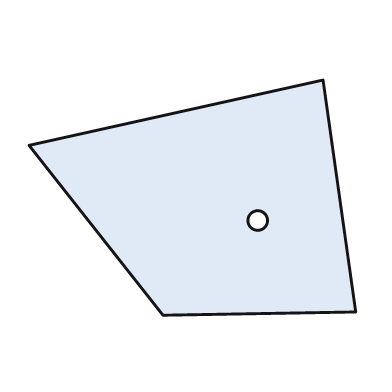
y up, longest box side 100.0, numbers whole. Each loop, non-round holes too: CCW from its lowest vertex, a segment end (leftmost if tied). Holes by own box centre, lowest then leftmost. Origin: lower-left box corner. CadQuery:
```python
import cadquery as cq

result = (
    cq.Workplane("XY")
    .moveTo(41.0, 0.0)
    .lineTo(100.0, 1.0)
    .lineTo(90.0, 72.0)
    .lineTo(0.0, 52.0)
    .close()
    .moveTo(70.0, 29.0)
    .circle(3.0)
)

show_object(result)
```